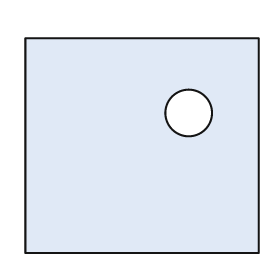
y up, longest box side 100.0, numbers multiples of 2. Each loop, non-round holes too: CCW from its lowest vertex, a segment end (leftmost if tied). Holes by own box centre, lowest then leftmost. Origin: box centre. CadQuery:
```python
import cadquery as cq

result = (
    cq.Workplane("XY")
    .moveTo(-50.0, -46.0)
    .lineTo(50.0, -46.0)
    .lineTo(50.0, 46.0)
    .lineTo(-50.0, 46.0)
    .close()
    .moveTo(20.0, 14.0)
    .circle(10.0)
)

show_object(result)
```